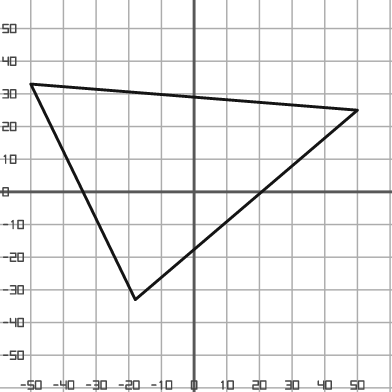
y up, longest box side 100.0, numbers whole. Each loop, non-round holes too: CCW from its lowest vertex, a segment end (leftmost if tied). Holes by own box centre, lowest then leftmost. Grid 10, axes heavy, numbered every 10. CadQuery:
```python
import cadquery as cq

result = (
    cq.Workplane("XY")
    .moveTo(-18.0, -33.0)
    .lineTo(50.0, 25.0)
    .lineTo(-50.0, 33.0)
    .close()
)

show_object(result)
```